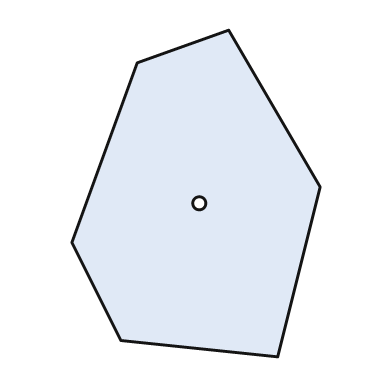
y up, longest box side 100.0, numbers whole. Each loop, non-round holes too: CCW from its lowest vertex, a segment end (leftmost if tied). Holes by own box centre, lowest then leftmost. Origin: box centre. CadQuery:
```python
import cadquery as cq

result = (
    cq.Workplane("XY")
    .moveTo(25.0, -50.0)
    .lineTo(38.0, 2.0)
    .lineTo(10.0, 50.0)
    .lineTo(-18.0, 40.0)
    .lineTo(-38.0, -15.0)
    .lineTo(-23.0, -45.0)
    .close()
    .moveTo(1.0, -3.0)
    .circle(2.0)
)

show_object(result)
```